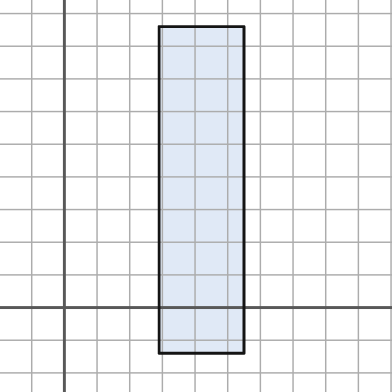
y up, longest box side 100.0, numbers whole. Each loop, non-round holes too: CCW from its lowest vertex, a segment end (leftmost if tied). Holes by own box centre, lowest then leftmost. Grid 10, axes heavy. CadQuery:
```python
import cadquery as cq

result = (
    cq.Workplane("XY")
    .moveTo(29.0, -14.0)
    .lineTo(55.0, -14.0)
    .lineTo(55.0, 86.0)
    .lineTo(29.0, 86.0)
    .close()
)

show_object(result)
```